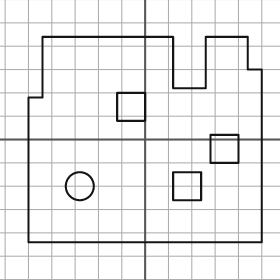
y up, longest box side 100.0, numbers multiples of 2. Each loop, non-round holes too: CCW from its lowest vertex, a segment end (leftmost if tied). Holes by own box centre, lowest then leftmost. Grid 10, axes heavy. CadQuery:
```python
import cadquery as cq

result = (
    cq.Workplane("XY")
    .moveTo(-50.0, -44.0)
    .lineTo(50.0, -44.0)
    .lineTo(50.0, 30.0)
    .lineTo(44.0, 30.0)
    .lineTo(44.0, 44.0)
    .lineTo(26.0, 44.0)
    .lineTo(26.0, 22.0)
    .lineTo(12.0, 22.0)
    .lineTo(12.0, 44.0)
    .lineTo(-44.0, 44.0)
    .lineTo(-44.0, 18.0)
    .lineTo(-50.0, 18.0)
    .close()
    .moveTo(-28.0, -20.0)
    .circle(6.0)
    .moveTo(12.0, -26.0)
    .lineTo(24.0, -26.0)
    .lineTo(24.0, -14.0)
    .lineTo(12.0, -14.0)
    .close()
    .moveTo(28.0, -10.0)
    .lineTo(40.0, -10.0)
    .lineTo(40.0, 2.0)
    .lineTo(28.0, 2.0)
    .close()
    .moveTo(-12.0, 8.0)
    .lineTo(0.0, 8.0)
    .lineTo(0.0, 20.0)
    .lineTo(-12.0, 20.0)
    .close()
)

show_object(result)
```